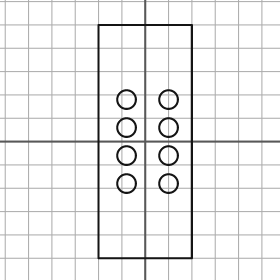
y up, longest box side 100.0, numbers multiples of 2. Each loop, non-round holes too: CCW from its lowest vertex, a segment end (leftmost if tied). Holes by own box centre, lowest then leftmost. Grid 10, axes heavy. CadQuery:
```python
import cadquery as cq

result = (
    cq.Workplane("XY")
    .moveTo(-20.0, -50.0)
    .lineTo(20.0, -50.0)
    .lineTo(20.0, 50.0)
    .lineTo(-20.0, 50.0)
    .close()
    .moveTo(-8.0, -18.0)
    .circle(4.0)
    .moveTo(10.0, -18.0)
    .circle(4.0)
    .moveTo(-8.0, -6.0)
    .circle(4.0)
    .moveTo(10.0, -6.0)
    .circle(4.0)
    .moveTo(-8.0, 6.0)
    .circle(4.0)
    .moveTo(10.0, 6.0)
    .circle(4.0)
    .moveTo(-8.0, 18.0)
    .circle(4.0)
    .moveTo(10.0, 18.0)
    .circle(4.0)
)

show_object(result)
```